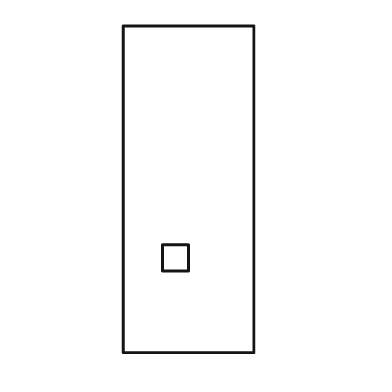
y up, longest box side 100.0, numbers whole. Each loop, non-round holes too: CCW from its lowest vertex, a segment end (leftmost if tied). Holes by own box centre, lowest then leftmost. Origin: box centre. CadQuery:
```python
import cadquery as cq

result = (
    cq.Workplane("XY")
    .moveTo(-20.0, -50.0)
    .lineTo(20.0, -50.0)
    .lineTo(20.0, 50.0)
    .lineTo(-20.0, 50.0)
    .close()
    .moveTo(-8.0, -25.0)
    .lineTo(0.0, -25.0)
    .lineTo(0.0, -17.0)
    .lineTo(-8.0, -17.0)
    .close()
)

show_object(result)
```